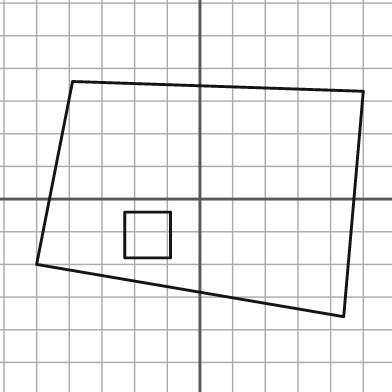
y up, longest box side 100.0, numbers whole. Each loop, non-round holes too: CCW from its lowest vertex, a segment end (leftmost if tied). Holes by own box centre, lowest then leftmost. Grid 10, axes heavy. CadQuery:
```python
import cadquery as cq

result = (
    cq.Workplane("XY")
    .moveTo(44.0, -36.0)
    .lineTo(50.0, 33.0)
    .lineTo(-39.0, 36.0)
    .lineTo(-50.0, -20.0)
    .close()
    .moveTo(-23.0, -18.0)
    .lineTo(-9.0, -18.0)
    .lineTo(-9.0, -4.0)
    .lineTo(-23.0, -4.0)
    .close()
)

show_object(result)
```